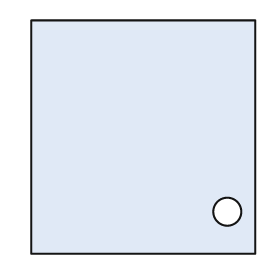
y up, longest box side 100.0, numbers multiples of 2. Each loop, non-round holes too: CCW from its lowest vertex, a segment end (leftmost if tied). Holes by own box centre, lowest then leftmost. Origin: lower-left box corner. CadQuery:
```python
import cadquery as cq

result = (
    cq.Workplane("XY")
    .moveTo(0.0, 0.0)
    .lineTo(96.0, 0.0)
    .lineTo(96.0, 100.0)
    .lineTo(0.0, 100.0)
    .close()
    .moveTo(84.0, 18.0)
    .circle(6.0)
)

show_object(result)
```